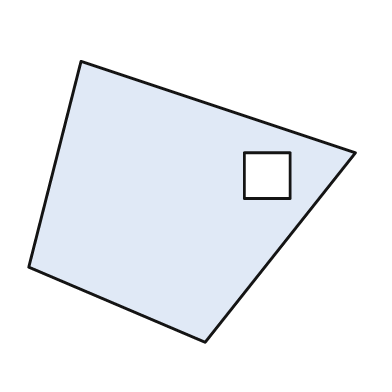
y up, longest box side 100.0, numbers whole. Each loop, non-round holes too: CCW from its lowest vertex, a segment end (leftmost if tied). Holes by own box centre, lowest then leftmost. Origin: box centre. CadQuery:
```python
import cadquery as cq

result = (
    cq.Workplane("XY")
    .moveTo(4.0, -43.0)
    .lineTo(50.0, 15.0)
    .lineTo(-34.0, 43.0)
    .lineTo(-50.0, -20.0)
    .close()
    .moveTo(16.0, 1.0)
    .lineTo(30.0, 1.0)
    .lineTo(30.0, 15.0)
    .lineTo(16.0, 15.0)
    .close()
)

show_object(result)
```